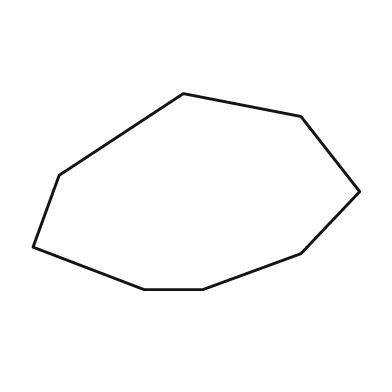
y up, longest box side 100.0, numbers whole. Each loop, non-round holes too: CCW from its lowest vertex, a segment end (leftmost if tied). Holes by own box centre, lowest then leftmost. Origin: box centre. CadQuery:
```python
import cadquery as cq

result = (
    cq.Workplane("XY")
    .moveTo(-16.0, -30.0)
    .lineTo(2.0, -30.0)
    .lineTo(32.0, -19.0)
    .lineTo(50.0, 0.0)
    .lineTo(32.0, 23.0)
    .lineTo(-4.0, 30.0)
    .lineTo(-42.0, 5.0)
    .lineTo(-50.0, -17.0)
    .close()
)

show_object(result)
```